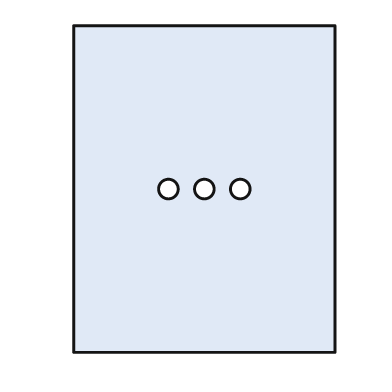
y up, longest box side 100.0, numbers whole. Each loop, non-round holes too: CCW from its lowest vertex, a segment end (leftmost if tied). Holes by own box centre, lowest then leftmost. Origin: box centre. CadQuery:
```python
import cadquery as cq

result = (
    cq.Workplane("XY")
    .moveTo(-40.0, -50.0)
    .lineTo(40.0, -50.0)
    .lineTo(40.0, 50.0)
    .lineTo(-40.0, 50.0)
    .close()
    .moveTo(-11.0, 0.0)
    .circle(3.0)
    .moveTo(0.0, 0.0)
    .circle(3.0)
    .moveTo(11.0, 0.0)
    .circle(3.0)
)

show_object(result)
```